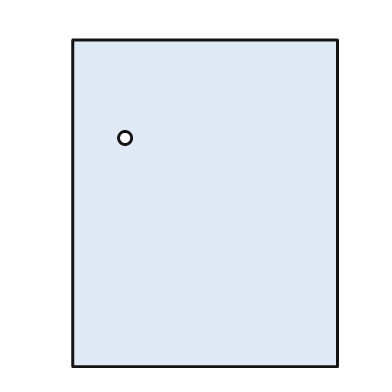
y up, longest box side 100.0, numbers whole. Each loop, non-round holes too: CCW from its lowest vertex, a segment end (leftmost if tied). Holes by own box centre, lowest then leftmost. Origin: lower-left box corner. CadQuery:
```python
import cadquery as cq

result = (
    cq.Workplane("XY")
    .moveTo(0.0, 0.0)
    .lineTo(81.0, 0.0)
    .lineTo(81.0, 100.0)
    .lineTo(0.0, 100.0)
    .close()
    .moveTo(16.0, 70.0)
    .circle(2.0)
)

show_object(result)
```